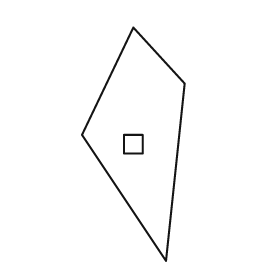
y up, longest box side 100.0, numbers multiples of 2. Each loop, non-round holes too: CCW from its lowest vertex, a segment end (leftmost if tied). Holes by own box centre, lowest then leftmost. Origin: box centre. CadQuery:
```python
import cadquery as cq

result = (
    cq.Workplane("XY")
    .moveTo(14.0, -50.0)
    .lineTo(22.0, 26.0)
    .lineTo(0.0, 50.0)
    .lineTo(-22.0, 4.0)
    .close()
    .moveTo(-4.0, -4.0)
    .lineTo(4.0, -4.0)
    .lineTo(4.0, 4.0)
    .lineTo(-4.0, 4.0)
    .close()
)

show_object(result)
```